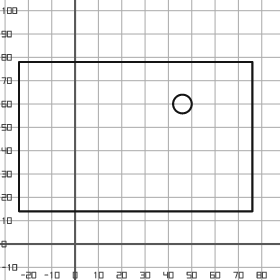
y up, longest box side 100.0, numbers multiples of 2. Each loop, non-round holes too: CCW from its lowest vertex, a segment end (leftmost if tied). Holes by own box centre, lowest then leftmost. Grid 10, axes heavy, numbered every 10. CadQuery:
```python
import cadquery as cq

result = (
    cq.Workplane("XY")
    .moveTo(-24.0, 14.0)
    .lineTo(76.0, 14.0)
    .lineTo(76.0, 78.0)
    .lineTo(-24.0, 78.0)
    .close()
    .moveTo(46.0, 60.0)
    .circle(4.0)
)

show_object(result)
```